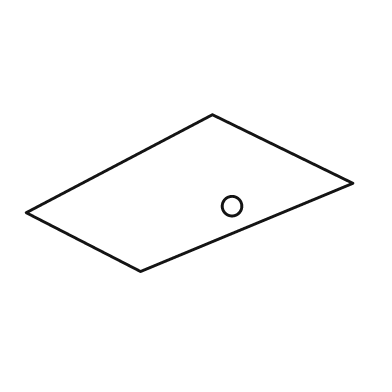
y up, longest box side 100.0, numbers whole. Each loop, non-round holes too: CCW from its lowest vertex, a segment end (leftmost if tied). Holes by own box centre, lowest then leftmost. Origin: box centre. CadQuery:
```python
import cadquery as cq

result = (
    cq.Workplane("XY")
    .moveTo(-15.0, -24.0)
    .lineTo(50.0, 3.0)
    .lineTo(7.0, 24.0)
    .lineTo(-50.0, -6.0)
    .close()
    .moveTo(13.0, -4.0)
    .circle(3.0)
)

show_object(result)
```